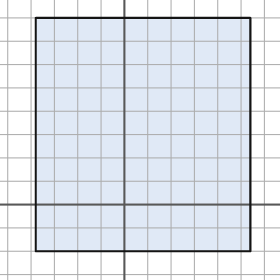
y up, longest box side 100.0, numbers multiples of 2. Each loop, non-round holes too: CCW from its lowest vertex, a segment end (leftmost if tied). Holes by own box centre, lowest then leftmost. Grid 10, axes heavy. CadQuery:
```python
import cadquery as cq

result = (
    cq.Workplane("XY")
    .moveTo(-38.0, -20.0)
    .lineTo(54.0, -20.0)
    .lineTo(54.0, 80.0)
    .lineTo(-38.0, 80.0)
    .close()
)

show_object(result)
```